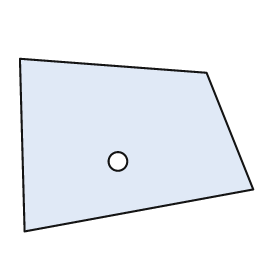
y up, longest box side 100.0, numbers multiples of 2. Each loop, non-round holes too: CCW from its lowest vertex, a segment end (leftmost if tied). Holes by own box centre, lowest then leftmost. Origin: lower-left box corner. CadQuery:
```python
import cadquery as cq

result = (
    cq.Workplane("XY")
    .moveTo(2.0, 0.0)
    .lineTo(100.0, 18.0)
    .lineTo(80.0, 68.0)
    .lineTo(0.0, 74.0)
    .close()
    .moveTo(42.0, 30.0)
    .circle(4.0)
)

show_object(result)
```